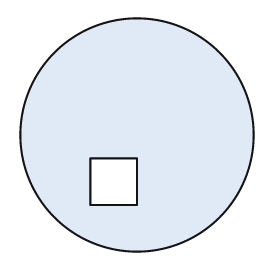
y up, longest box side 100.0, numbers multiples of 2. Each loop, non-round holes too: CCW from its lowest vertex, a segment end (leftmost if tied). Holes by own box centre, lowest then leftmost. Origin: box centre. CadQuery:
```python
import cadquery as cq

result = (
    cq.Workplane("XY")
    .moveTo(0.0, 0.0)
    .circle(50.0)
    .moveTo(-20.0, -30.0)
    .lineTo(0.0, -30.0)
    .lineTo(0.0, -10.0)
    .lineTo(-20.0, -10.0)
    .close()
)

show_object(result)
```